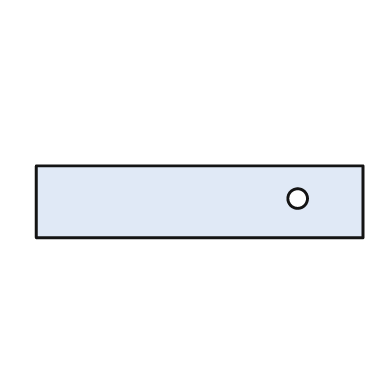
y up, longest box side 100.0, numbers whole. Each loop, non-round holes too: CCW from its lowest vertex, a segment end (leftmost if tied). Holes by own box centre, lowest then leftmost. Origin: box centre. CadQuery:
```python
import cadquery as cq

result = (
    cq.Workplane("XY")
    .moveTo(-50.0, -11.0)
    .lineTo(50.0, -11.0)
    .lineTo(50.0, 11.0)
    .lineTo(-50.0, 11.0)
    .close()
    .moveTo(30.0, 1.0)
    .circle(3.0)
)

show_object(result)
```